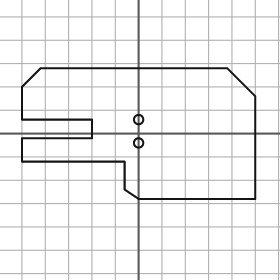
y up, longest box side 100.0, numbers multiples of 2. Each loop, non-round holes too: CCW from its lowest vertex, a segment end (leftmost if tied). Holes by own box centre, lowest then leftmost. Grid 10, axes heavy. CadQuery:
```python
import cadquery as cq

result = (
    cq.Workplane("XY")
    .moveTo(0.0, -28.0)
    .lineTo(50.0, -28.0)
    .lineTo(50.0, 16.0)
    .lineTo(38.0, 28.0)
    .lineTo(-42.0, 28.0)
    .lineTo(-50.0, 20.0)
    .lineTo(-50.0, 6.0)
    .lineTo(-20.0, 6.0)
    .lineTo(-20.0, -2.0)
    .lineTo(-50.0, -2.0)
    .lineTo(-50.0, -12.0)
    .lineTo(-6.0, -12.0)
    .lineTo(-6.0, -24.0)
    .close()
    .moveTo(0.0, -4.0)
    .circle(2.0)
    .moveTo(0.0, 6.0)
    .circle(2.0)
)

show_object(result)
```